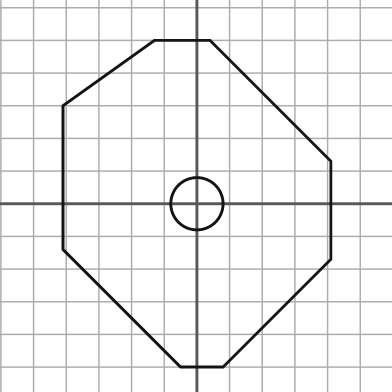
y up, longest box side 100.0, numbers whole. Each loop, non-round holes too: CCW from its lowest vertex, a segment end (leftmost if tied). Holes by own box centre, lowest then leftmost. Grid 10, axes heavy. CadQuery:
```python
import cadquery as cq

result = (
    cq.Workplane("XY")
    .moveTo(-5.0, -50.0)
    .lineTo(8.0, -50.0)
    .lineTo(41.0, -17.0)
    .lineTo(41.0, 13.0)
    .lineTo(4.0, 50.0)
    .lineTo(-13.0, 50.0)
    .lineTo(-41.0, 30.0)
    .lineTo(-41.0, -14.0)
    .close()
    .moveTo(0.0, 0.0)
    .circle(8.0)
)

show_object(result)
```